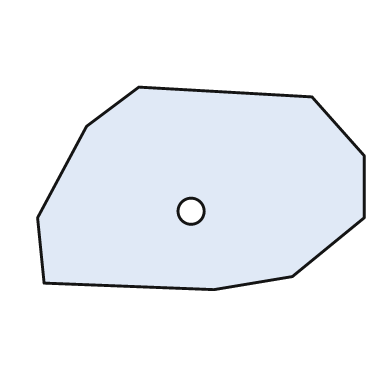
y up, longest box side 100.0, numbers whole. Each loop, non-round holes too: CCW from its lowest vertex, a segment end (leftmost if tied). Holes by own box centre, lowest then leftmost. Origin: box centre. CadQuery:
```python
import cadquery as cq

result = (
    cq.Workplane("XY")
    .moveTo(4.0, -31.0)
    .lineTo(28.0, -27.0)
    .lineTo(50.0, -9.0)
    .lineTo(50.0, 10.0)
    .lineTo(34.0, 28.0)
    .lineTo(-19.0, 31.0)
    .lineTo(-35.0, 19.0)
    .lineTo(-50.0, -9.0)
    .lineTo(-48.0, -29.0)
    .close()
    .moveTo(-3.0, -7.0)
    .circle(4.0)
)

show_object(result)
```